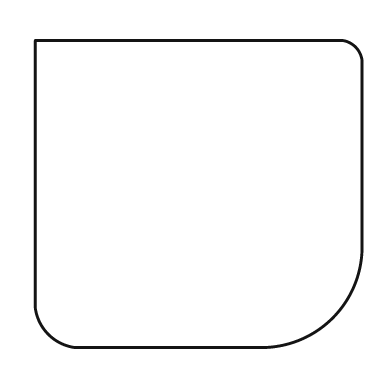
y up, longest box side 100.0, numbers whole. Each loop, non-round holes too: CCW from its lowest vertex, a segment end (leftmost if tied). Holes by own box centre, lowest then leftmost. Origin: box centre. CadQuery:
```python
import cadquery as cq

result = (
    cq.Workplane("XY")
    .moveTo(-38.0, -47.0)
    .lineTo(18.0, -47.0)
    .threePointArc((41.0, -38.0), (50.0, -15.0))
    .lineTo(50.0, 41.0)
    .threePointArc((48.0, 45.0), (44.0, 47.0))
    .lineTo(-50.0, 47.0)
    .lineTo(-50.0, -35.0)
    .threePointArc((-46.0, -43.0), (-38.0, -47.0))
    .close()
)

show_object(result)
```